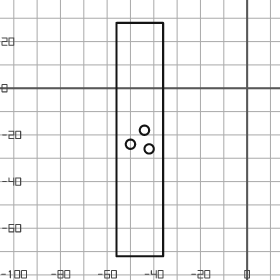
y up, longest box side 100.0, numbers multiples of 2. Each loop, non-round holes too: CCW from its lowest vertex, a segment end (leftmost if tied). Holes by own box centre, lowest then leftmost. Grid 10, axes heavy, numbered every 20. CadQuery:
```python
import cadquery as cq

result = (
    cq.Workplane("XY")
    .moveTo(-56.0, -72.0)
    .lineTo(-36.0, -72.0)
    .lineTo(-36.0, 28.0)
    .lineTo(-56.0, 28.0)
    .close()
    .moveTo(-42.0, -26.0)
    .circle(2.0)
    .moveTo(-50.0, -24.0)
    .circle(2.0)
    .moveTo(-44.0, -18.0)
    .circle(2.0)
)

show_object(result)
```